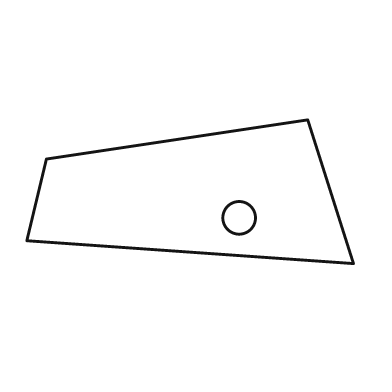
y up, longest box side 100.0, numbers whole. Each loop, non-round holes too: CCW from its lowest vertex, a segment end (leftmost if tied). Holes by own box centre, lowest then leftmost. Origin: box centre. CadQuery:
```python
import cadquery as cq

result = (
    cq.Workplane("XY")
    .moveTo(50.0, -22.0)
    .lineTo(36.0, 22.0)
    .lineTo(-44.0, 10.0)
    .lineTo(-50.0, -15.0)
    .close()
    .moveTo(15.0, -8.0)
    .circle(5.0)
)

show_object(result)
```